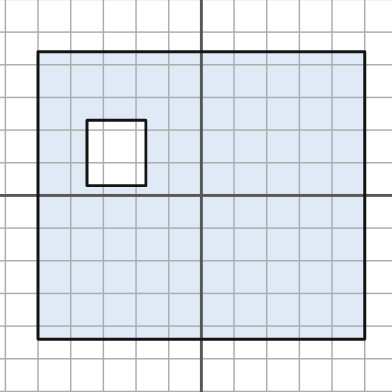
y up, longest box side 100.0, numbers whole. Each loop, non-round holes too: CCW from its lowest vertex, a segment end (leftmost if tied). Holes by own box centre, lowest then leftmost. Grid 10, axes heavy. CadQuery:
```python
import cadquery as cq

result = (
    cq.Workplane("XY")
    .moveTo(-50.0, -44.0)
    .lineTo(50.0, -44.0)
    .lineTo(50.0, 44.0)
    .lineTo(-50.0, 44.0)
    .close()
    .moveTo(-35.0, 3.0)
    .lineTo(-17.0, 3.0)
    .lineTo(-17.0, 23.0)
    .lineTo(-35.0, 23.0)
    .close()
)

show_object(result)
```